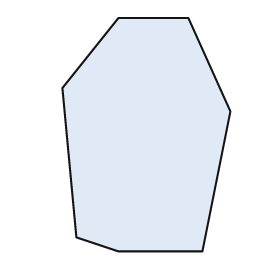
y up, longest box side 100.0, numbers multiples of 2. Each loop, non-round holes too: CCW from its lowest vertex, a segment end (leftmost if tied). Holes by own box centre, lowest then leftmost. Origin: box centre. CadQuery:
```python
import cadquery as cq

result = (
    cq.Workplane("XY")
    .moveTo(-12.0, -50.0)
    .lineTo(24.0, -50.0)
    .lineTo(36.0, 10.0)
    .lineTo(18.0, 50.0)
    .lineTo(-12.0, 50.0)
    .lineTo(-36.0, 20.0)
    .lineTo(-30.0, -44.0)
    .close()
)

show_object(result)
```